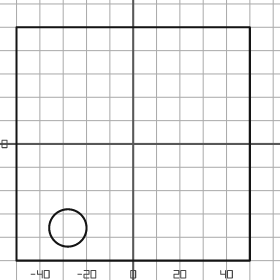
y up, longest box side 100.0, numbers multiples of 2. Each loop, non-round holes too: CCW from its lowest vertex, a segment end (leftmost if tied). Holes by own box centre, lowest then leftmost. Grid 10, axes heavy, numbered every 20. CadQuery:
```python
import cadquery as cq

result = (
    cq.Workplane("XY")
    .moveTo(-50.0, -50.0)
    .lineTo(50.0, -50.0)
    .lineTo(50.0, 50.0)
    .lineTo(-50.0, 50.0)
    .close()
    .moveTo(-28.0, -36.0)
    .circle(8.0)
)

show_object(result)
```